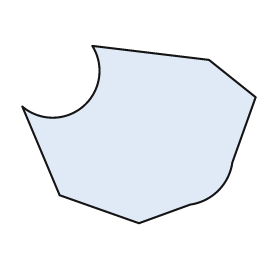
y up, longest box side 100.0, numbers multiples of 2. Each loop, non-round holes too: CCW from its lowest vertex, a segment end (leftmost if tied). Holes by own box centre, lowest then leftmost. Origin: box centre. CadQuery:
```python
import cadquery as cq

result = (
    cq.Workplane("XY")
    .moveTo(0.0, -38.0)
    .lineTo(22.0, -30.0)
    .threePointArc((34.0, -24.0), (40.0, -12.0))
    .lineTo(50.0, 16.0)
    .lineTo(30.0, 32.0)
    .lineTo(-20.0, 38.0)
    .threePointArc((-24.0, 12.0), (-50.0, 12.0))
    .lineTo(-34.0, -26.0)
    .close()
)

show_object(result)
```